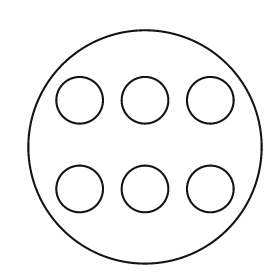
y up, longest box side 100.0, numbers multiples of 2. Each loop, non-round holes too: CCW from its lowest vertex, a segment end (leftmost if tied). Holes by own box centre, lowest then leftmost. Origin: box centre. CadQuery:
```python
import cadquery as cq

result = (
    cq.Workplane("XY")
    .moveTo(0.0, 0.0)
    .circle(50.0)
    .moveTo(-28.0, -18.0)
    .circle(10.0)
    .moveTo(0.0, -18.0)
    .circle(10.0)
    .moveTo(28.0, -18.0)
    .circle(10.0)
    .moveTo(-28.0, 20.0)
    .circle(10.0)
    .moveTo(0.0, 20.0)
    .circle(10.0)
    .moveTo(28.0, 20.0)
    .circle(10.0)
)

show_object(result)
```